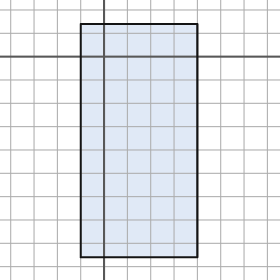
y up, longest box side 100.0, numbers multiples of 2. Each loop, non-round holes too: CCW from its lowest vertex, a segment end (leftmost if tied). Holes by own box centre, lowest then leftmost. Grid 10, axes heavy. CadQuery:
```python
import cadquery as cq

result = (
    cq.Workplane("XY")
    .moveTo(-10.0, -86.0)
    .lineTo(40.0, -86.0)
    .lineTo(40.0, 14.0)
    .lineTo(-10.0, 14.0)
    .close()
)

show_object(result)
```